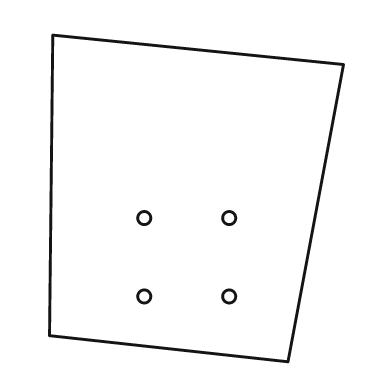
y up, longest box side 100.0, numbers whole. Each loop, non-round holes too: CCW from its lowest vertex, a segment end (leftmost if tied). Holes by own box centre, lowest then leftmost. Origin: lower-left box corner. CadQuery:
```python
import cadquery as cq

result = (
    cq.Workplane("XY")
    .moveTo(73.0, 0.0)
    .lineTo(90.0, 91.0)
    .lineTo(1.0, 100.0)
    .lineTo(0.0, 8.0)
    .close()
    .moveTo(29.0, 20.0)
    .circle(2.0)
    .moveTo(55.0, 20.0)
    .circle(2.0)
    .moveTo(29.0, 44.0)
    .circle(2.0)
    .moveTo(55.0, 44.0)
    .circle(2.0)
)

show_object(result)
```